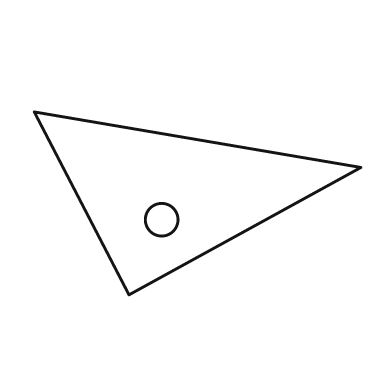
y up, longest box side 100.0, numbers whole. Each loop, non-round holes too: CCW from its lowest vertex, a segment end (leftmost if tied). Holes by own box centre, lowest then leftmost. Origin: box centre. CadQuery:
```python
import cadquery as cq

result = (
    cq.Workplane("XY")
    .moveTo(-21.0, -28.0)
    .lineTo(50.0, 11.0)
    .lineTo(-50.0, 28.0)
    .close()
    .moveTo(-11.0, -5.0)
    .circle(5.0)
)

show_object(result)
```